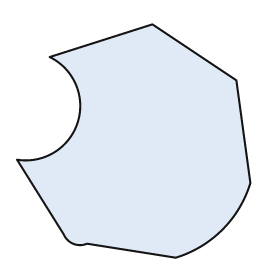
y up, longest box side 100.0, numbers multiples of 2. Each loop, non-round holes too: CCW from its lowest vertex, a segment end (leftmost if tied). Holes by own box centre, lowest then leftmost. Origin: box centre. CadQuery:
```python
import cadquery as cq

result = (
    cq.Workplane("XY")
    .moveTo(18.0, -50.0)
    .threePointArc((38.0, -38.0), (50.0, -18.0))
    .lineTo(44.0, 26.0)
    .lineTo(8.0, 50.0)
    .lineTo(-36.0, 36.0)
    .threePointArc((-24.0, 8.0), (-50.0, -8.0))
    .lineTo(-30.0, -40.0)
    .threePointArc((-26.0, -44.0), (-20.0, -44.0))
    .close()
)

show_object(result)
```